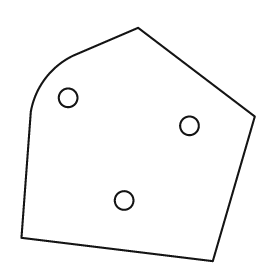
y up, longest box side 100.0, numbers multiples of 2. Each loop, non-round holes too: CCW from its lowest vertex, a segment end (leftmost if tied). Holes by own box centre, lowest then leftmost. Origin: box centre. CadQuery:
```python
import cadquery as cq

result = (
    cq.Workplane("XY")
    .moveTo(32.0, -50.0)
    .lineTo(50.0, 12.0)
    .lineTo(0.0, 50.0)
    .lineTo(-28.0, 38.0)
    .threePointArc((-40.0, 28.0), (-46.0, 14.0))
    .lineTo(-50.0, -40.0)
    .close()
    .moveTo(-6.0, -24.0)
    .circle(4.0)
    .moveTo(22.0, 8.0)
    .circle(4.0)
    .moveTo(-30.0, 20.0)
    .circle(4.0)
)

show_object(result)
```